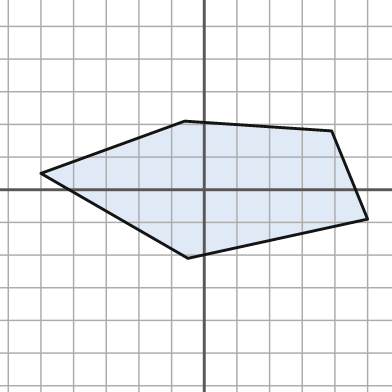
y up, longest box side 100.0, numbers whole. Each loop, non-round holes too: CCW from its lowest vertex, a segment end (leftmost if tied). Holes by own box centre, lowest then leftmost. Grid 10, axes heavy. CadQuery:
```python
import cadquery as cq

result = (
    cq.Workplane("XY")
    .moveTo(-5.0, -21.0)
    .lineTo(50.0, -9.0)
    .lineTo(39.0, 18.0)
    .lineTo(-6.0, 21.0)
    .lineTo(-50.0, 5.0)
    .close()
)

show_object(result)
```